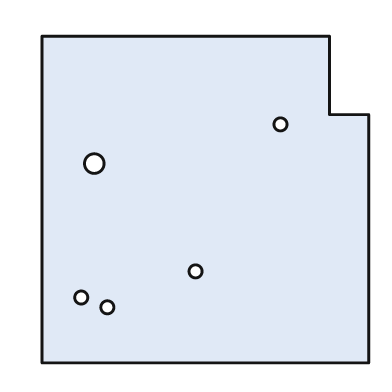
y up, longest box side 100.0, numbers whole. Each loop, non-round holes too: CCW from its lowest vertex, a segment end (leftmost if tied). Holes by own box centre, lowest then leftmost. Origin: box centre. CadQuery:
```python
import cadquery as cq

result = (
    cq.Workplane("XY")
    .moveTo(-50.0, -50.0)
    .lineTo(50.0, -50.0)
    .lineTo(50.0, 26.0)
    .lineTo(38.0, 26.0)
    .lineTo(38.0, 50.0)
    .lineTo(-50.0, 50.0)
    .close()
    .moveTo(-30.0, -33.0)
    .circle(2.0)
    .moveTo(-38.0, -30.0)
    .circle(2.0)
    .moveTo(-3.0, -22.0)
    .circle(2.0)
    .moveTo(-34.0, 11.0)
    .circle(3.0)
    .moveTo(23.0, 23.0)
    .circle(2.0)
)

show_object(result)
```